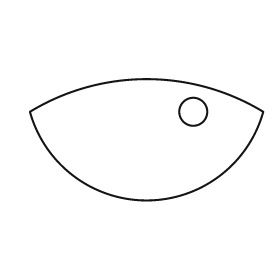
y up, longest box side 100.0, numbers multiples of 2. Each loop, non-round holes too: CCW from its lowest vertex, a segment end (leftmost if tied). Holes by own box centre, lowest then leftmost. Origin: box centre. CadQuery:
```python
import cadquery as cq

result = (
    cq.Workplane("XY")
    .moveTo(-50.0, 12.0)
    .threePointArc((0.0, -26.0), (50.0, 12.0))
    .threePointArc((0.0, 26.0), (-50.0, 12.0))
    .close()
    .moveTo(20.0, 12.0)
    .circle(6.0)
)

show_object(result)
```